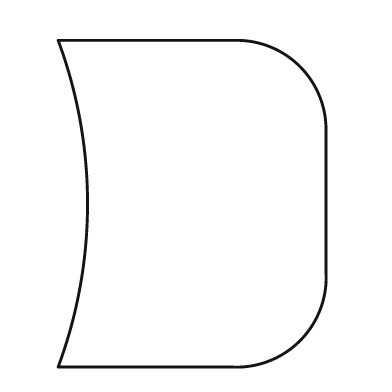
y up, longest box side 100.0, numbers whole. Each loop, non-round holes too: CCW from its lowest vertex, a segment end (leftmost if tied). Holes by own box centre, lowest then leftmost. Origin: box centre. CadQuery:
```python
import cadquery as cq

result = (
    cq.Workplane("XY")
    .moveTo(-41.0, -50.0)
    .lineTo(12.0, -50.0)
    .threePointArc((33.0, -42.0), (41.0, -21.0))
    .lineTo(41.0, 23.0)
    .threePointArc((33.0, 42.0), (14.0, 50.0))
    .lineTo(-41.0, 50.0)
    .threePointArc((-32.0, 0.0), (-41.0, -50.0))
    .close()
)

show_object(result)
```